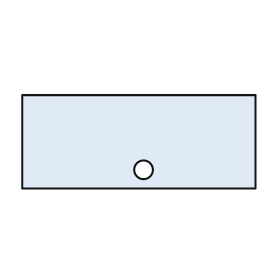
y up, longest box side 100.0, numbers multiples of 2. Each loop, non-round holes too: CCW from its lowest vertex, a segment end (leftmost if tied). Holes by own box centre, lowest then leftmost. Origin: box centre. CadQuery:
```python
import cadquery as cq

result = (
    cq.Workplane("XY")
    .moveTo(-50.0, -20.0)
    .lineTo(50.0, -20.0)
    .lineTo(50.0, 20.0)
    .lineTo(-50.0, 20.0)
    .close()
    .moveTo(2.0, -12.0)
    .circle(4.0)
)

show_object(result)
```